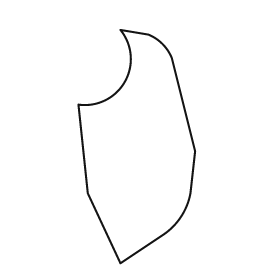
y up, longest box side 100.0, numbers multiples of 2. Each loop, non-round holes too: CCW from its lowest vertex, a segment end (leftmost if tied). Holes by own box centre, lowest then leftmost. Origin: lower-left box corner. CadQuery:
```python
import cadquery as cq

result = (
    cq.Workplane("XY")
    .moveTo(18.0, 0.0)
    .lineTo(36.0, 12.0)
    .threePointArc((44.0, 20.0), (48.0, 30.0))
    .lineTo(50.0, 48.0)
    .lineTo(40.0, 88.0)
    .threePointArc((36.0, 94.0), (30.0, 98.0))
    .lineTo(18.0, 100.0)
    .threePointArc((20.0, 78.0), (0.0, 68.0))
    .lineTo(4.0, 30.0)
    .close()
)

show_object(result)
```